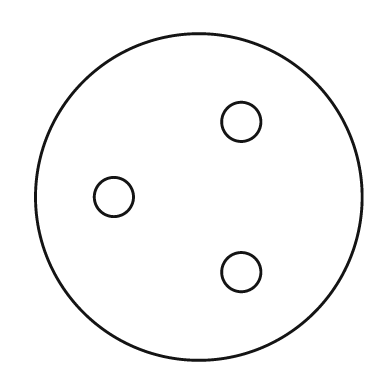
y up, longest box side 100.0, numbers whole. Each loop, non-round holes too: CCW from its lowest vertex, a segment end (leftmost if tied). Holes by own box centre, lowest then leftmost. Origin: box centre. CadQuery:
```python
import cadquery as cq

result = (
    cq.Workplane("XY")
    .moveTo(0.0, 0.0)
    .circle(50.0)
    .moveTo(13.0, -23.0)
    .circle(6.0)
    .moveTo(-26.0, 0.0)
    .circle(6.0)
    .moveTo(13.0, 23.0)
    .circle(6.0)
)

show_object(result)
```